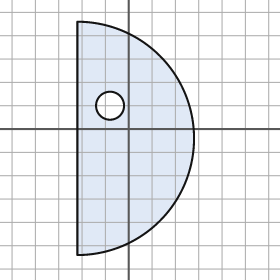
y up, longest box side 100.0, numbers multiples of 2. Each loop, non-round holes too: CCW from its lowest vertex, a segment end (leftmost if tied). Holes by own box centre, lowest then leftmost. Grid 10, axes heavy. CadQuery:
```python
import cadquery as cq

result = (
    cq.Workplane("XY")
    .moveTo(-22.0, -54.0)
    .threePointArc((28.0, -4.0), (-22.0, 46.0))
    .close()
    .moveTo(-8.0, 10.0)
    .circle(6.0)
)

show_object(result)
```